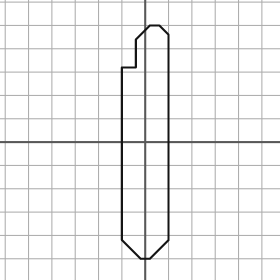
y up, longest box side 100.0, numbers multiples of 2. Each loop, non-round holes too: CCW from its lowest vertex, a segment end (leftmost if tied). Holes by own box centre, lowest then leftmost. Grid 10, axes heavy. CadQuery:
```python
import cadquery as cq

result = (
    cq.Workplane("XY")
    .moveTo(-2.0, -50.0)
    .lineTo(2.0, -50.0)
    .lineTo(10.0, -42.0)
    .lineTo(10.0, 46.0)
    .lineTo(6.0, 50.0)
    .lineTo(2.0, 50.0)
    .lineTo(-4.0, 44.0)
    .lineTo(-4.0, 32.0)
    .lineTo(-10.0, 32.0)
    .lineTo(-10.0, -42.0)
    .close()
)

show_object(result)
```